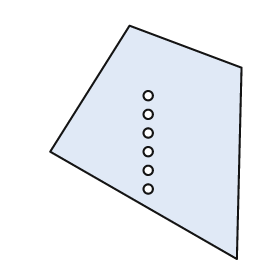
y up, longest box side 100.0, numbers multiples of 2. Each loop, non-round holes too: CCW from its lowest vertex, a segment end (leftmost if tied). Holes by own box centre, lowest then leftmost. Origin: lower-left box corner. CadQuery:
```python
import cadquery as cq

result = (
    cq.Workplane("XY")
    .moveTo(80.0, 0.0)
    .lineTo(82.0, 82.0)
    .lineTo(34.0, 100.0)
    .lineTo(0.0, 46.0)
    .close()
    .moveTo(42.0, 30.0)
    .circle(2.0)
    .moveTo(42.0, 38.0)
    .circle(2.0)
    .moveTo(42.0, 46.0)
    .circle(2.0)
    .moveTo(42.0, 54.0)
    .circle(2.0)
    .moveTo(42.0, 62.0)
    .circle(2.0)
    .moveTo(42.0, 70.0)
    .circle(2.0)
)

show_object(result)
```